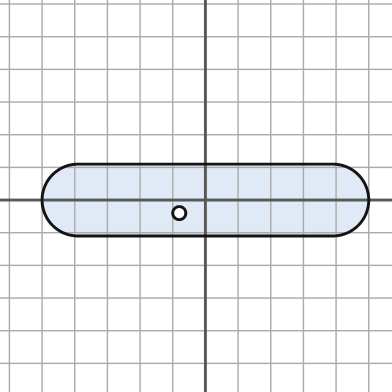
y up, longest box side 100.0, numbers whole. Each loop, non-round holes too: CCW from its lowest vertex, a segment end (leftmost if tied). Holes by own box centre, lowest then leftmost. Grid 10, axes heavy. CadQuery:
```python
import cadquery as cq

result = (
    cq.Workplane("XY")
    .moveTo(-39.0, -11.0)
    .lineTo(39.0, -11.0)
    .threePointArc((50.0, 0.0), (39.0, 11.0))
    .lineTo(-39.0, 11.0)
    .threePointArc((-50.0, 0.0), (-39.0, -11.0))
    .close()
    .moveTo(-8.0, -4.0)
    .circle(2.0)
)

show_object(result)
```